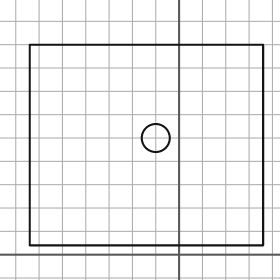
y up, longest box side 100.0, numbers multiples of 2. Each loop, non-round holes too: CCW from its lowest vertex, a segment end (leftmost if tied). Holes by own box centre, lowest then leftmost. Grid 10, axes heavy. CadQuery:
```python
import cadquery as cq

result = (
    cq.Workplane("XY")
    .moveTo(-64.0, 4.0)
    .lineTo(36.0, 4.0)
    .lineTo(36.0, 90.0)
    .lineTo(-64.0, 90.0)
    .close()
    .moveTo(-10.0, 50.0)
    .circle(6.0)
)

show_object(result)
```